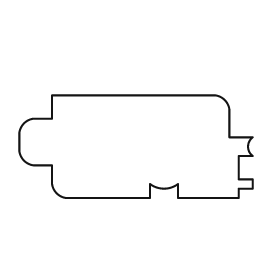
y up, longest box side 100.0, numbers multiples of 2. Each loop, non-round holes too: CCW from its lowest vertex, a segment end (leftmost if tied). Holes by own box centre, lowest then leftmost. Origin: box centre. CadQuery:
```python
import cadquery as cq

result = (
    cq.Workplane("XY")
    .moveTo(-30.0, -22.0)
    .lineTo(6.0, -22.0)
    .lineTo(6.0, -16.0)
    .threePointArc((12.0, -18.0), (18.0, -16.0))
    .lineTo(18.0, -22.0)
    .lineTo(44.0, -22.0)
    .lineTo(44.0, -18.0)
    .lineTo(50.0, -18.0)
    .lineTo(50.0, -14.0)
    .lineTo(44.0, -14.0)
    .lineTo(44.0, -4.0)
    .lineTo(50.0, -4.0)
    .threePointArc((48.0, 0.0), (50.0, 4.0))
    .lineTo(40.0, 4.0)
    .lineTo(40.0, 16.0)
    .threePointArc((38.0, 20.0), (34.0, 22.0))
    .lineTo(-36.0, 22.0)
    .lineTo(-36.0, 12.0)
    .lineTo(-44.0, 12.0)
    .threePointArc((-48.0, 10.0), (-50.0, 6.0))
    .lineTo(-50.0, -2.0)
    .threePointArc((-48.0, -6.0), (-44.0, -8.0))
    .lineTo(-36.0, -8.0)
    .lineTo(-36.0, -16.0)
    .threePointArc((-34.0, -20.0), (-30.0, -22.0))
    .close()
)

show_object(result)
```